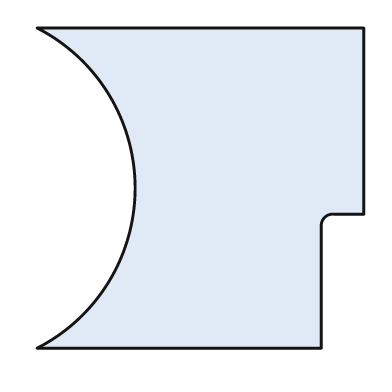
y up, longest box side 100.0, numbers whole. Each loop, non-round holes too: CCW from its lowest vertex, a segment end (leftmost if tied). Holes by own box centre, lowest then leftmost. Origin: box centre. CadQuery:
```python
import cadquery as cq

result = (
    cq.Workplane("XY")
    .moveTo(-50.0, -49.0)
    .lineTo(37.0, -49.0)
    .lineTo(37.0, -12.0)
    .threePointArc((38.0, -9.0), (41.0, -8.0))
    .lineTo(50.0, -8.0)
    .lineTo(50.0, 49.0)
    .lineTo(-50.0, 49.0)
    .threePointArc((-20.0, 0.0), (-50.0, -49.0))
    .close()
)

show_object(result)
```